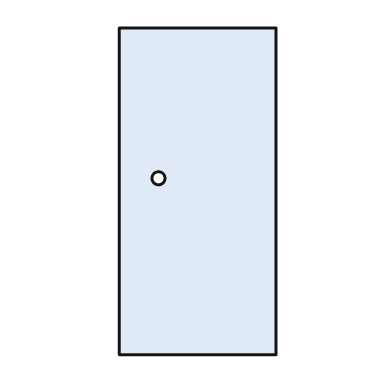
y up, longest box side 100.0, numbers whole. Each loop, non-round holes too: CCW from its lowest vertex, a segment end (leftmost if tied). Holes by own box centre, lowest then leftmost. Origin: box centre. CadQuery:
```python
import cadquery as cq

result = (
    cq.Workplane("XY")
    .moveTo(-24.0, -50.0)
    .lineTo(24.0, -50.0)
    .lineTo(24.0, 50.0)
    .lineTo(-24.0, 50.0)
    .close()
    .moveTo(-12.0, 4.0)
    .circle(2.0)
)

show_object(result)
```